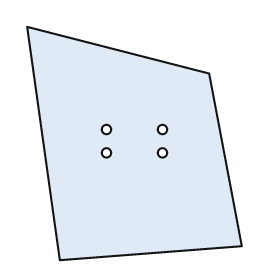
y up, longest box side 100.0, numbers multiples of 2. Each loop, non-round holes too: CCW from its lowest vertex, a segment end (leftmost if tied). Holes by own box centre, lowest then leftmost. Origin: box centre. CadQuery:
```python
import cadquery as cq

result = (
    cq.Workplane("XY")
    .moveTo(-32.0, -50.0)
    .lineTo(46.0, -44.0)
    .lineTo(32.0, 30.0)
    .lineTo(-46.0, 50.0)
    .close()
    .moveTo(-12.0, -4.0)
    .circle(2.0)
    .moveTo(12.0, -4.0)
    .circle(2.0)
    .moveTo(-12.0, 6.0)
    .circle(2.0)
    .moveTo(12.0, 6.0)
    .circle(2.0)
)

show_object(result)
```